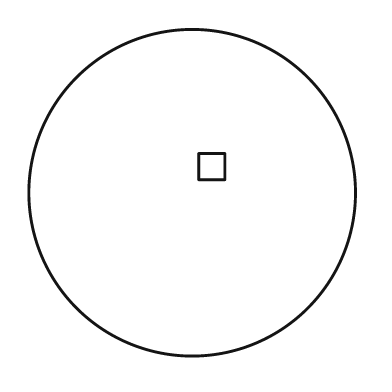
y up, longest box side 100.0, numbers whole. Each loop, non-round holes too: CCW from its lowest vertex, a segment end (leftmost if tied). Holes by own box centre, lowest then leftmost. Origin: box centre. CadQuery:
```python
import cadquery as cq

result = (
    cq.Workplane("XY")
    .moveTo(0.0, 0.0)
    .circle(50.0)
    .moveTo(2.0, 4.0)
    .lineTo(10.0, 4.0)
    .lineTo(10.0, 12.0)
    .lineTo(2.0, 12.0)
    .close()
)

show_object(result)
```